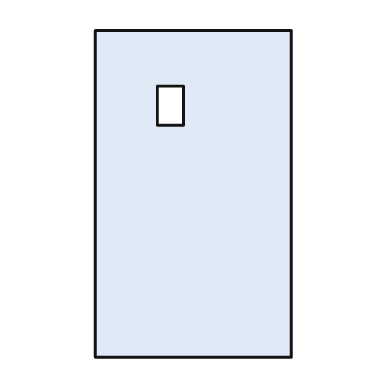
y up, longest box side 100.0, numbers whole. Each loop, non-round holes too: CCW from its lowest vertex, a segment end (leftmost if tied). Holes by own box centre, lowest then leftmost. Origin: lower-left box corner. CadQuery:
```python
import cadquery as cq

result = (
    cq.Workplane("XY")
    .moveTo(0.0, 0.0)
    .lineTo(60.0, 0.0)
    .lineTo(60.0, 100.0)
    .lineTo(0.0, 100.0)
    .close()
    .moveTo(19.0, 71.0)
    .lineTo(27.0, 71.0)
    .lineTo(27.0, 83.0)
    .lineTo(19.0, 83.0)
    .close()
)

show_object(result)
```